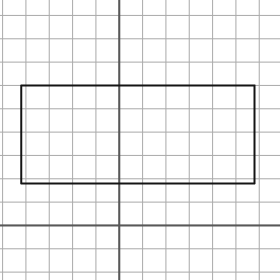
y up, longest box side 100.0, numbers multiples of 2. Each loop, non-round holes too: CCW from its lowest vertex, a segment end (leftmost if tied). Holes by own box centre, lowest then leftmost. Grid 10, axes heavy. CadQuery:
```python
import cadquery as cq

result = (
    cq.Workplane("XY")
    .moveTo(-42.0, 18.0)
    .lineTo(58.0, 18.0)
    .lineTo(58.0, 60.0)
    .lineTo(-42.0, 60.0)
    .close()
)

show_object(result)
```